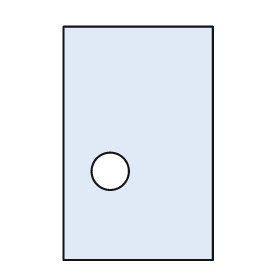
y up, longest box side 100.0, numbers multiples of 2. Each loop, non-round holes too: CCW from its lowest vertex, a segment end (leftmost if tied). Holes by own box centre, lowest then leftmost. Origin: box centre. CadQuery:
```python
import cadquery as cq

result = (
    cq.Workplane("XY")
    .moveTo(-32.0, -50.0)
    .lineTo(32.0, -50.0)
    .lineTo(32.0, 50.0)
    .lineTo(-32.0, 50.0)
    .close()
    .moveTo(-12.0, -12.0)
    .circle(8.0)
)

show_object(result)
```